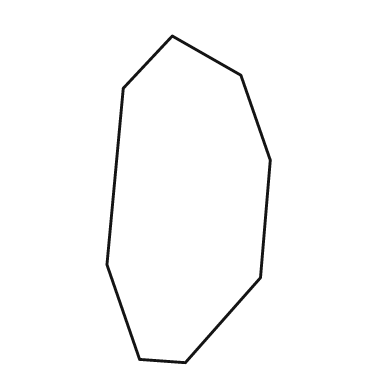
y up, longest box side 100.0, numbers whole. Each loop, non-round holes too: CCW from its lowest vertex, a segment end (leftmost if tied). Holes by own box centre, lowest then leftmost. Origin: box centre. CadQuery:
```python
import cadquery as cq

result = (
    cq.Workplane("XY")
    .moveTo(-1.0, -50.0)
    .lineTo(22.0, -24.0)
    .lineTo(25.0, 12.0)
    .lineTo(16.0, 38.0)
    .lineTo(-5.0, 50.0)
    .lineTo(-20.0, 34.0)
    .lineTo(-25.0, -20.0)
    .lineTo(-15.0, -49.0)
    .close()
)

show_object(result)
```